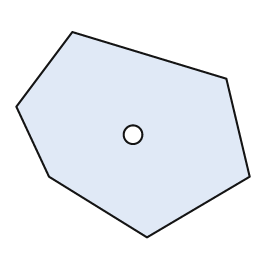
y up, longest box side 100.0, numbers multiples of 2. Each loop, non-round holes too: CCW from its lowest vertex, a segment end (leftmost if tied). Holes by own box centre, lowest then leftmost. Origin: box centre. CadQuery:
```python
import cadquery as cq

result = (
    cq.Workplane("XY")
    .moveTo(6.0, -44.0)
    .lineTo(50.0, -18.0)
    .lineTo(40.0, 24.0)
    .lineTo(-26.0, 44.0)
    .lineTo(-50.0, 12.0)
    .lineTo(-36.0, -18.0)
    .close()
    .moveTo(0.0, 0.0)
    .circle(4.0)
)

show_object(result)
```